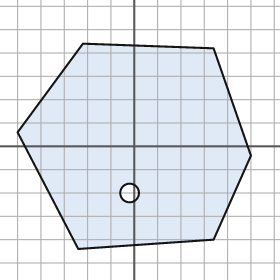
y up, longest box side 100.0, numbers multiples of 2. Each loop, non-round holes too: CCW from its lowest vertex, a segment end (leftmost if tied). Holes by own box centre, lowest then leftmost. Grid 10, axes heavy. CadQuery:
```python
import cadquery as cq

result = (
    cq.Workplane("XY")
    .moveTo(-24.0, -44.0)
    .lineTo(34.0, -40.0)
    .lineTo(50.0, -4.0)
    .lineTo(34.0, 42.0)
    .lineTo(-22.0, 44.0)
    .lineTo(-50.0, 6.0)
    .close()
    .moveTo(-2.0, -20.0)
    .circle(4.0)
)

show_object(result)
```